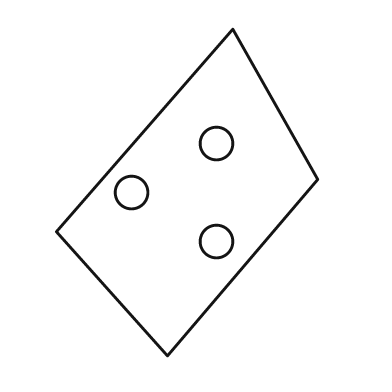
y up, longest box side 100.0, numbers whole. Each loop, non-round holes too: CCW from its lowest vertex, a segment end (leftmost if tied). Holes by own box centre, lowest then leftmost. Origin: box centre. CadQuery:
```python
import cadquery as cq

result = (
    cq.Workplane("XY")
    .moveTo(-6.0, -50.0)
    .lineTo(40.0, 4.0)
    .lineTo(14.0, 50.0)
    .lineTo(-40.0, -12.0)
    .close()
    .moveTo(9.0, -15.0)
    .circle(5.0)
    .moveTo(-17.0, 0.0)
    .circle(5.0)
    .moveTo(9.0, 15.0)
    .circle(5.0)
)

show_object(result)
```